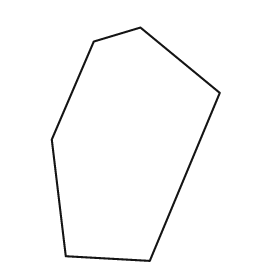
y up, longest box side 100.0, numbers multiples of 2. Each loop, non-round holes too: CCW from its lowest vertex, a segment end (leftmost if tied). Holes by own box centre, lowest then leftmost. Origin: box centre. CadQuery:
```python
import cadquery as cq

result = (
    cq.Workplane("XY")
    .moveTo(6.0, -50.0)
    .lineTo(36.0, 22.0)
    .lineTo(2.0, 50.0)
    .lineTo(-18.0, 44.0)
    .lineTo(-36.0, 2.0)
    .lineTo(-30.0, -48.0)
    .close()
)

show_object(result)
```